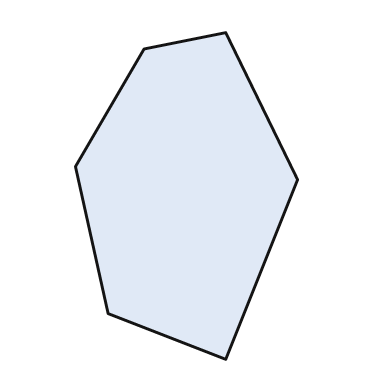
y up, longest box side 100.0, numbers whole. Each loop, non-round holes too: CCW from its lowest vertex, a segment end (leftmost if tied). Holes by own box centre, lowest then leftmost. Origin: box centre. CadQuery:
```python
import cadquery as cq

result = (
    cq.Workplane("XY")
    .moveTo(12.0, -50.0)
    .lineTo(34.0, 5.0)
    .lineTo(12.0, 50.0)
    .lineTo(-13.0, 45.0)
    .lineTo(-34.0, 9.0)
    .lineTo(-24.0, -36.0)
    .close()
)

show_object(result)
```